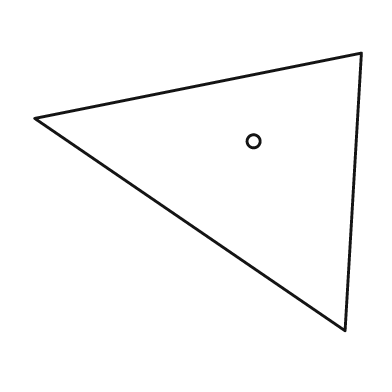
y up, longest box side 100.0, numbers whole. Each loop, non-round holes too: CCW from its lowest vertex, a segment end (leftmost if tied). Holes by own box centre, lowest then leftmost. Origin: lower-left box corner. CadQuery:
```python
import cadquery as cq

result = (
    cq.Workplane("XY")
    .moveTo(95.0, 0.0)
    .lineTo(100.0, 85.0)
    .lineTo(0.0, 65.0)
    .close()
    .moveTo(67.0, 58.0)
    .circle(2.0)
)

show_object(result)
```